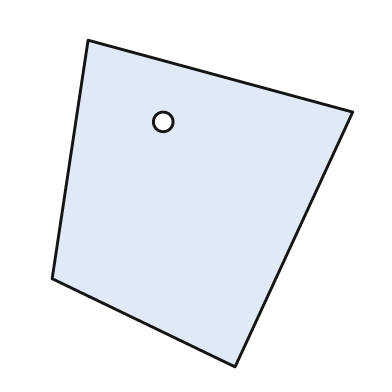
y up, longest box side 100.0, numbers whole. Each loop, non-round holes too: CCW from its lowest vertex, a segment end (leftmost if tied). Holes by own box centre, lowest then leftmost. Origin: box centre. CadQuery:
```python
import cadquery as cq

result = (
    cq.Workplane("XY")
    .moveTo(10.0, -50.0)
    .lineTo(46.0, 28.0)
    .lineTo(-35.0, 50.0)
    .lineTo(-46.0, -23.0)
    .close()
    .moveTo(-12.0, 25.0)
    .circle(3.0)
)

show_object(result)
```